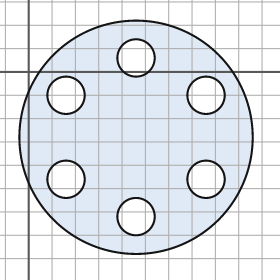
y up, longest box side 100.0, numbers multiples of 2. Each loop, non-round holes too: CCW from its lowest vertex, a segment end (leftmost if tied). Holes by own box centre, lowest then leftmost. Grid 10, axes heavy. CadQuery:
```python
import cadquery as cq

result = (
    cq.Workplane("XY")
    .moveTo(46.0, -28.0)
    .circle(50.0)
    .moveTo(46.0, -62.0)
    .circle(8.0)
    .moveTo(16.0, -46.0)
    .circle(8.0)
    .moveTo(76.0, -46.0)
    .circle(8.0)
    .moveTo(16.0, -10.0)
    .circle(8.0)
    .moveTo(76.0, -10.0)
    .circle(8.0)
    .moveTo(46.0, 6.0)
    .circle(8.0)
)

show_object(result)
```